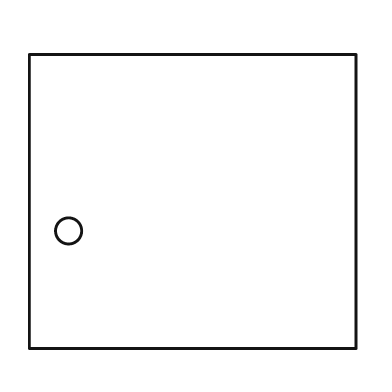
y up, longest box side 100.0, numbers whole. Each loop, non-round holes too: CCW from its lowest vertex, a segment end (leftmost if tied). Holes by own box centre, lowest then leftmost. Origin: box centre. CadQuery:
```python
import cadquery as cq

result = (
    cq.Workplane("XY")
    .moveTo(-50.0, -45.0)
    .lineTo(50.0, -45.0)
    .lineTo(50.0, 45.0)
    .lineTo(-50.0, 45.0)
    .close()
    .moveTo(-38.0, -9.0)
    .circle(4.0)
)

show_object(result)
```